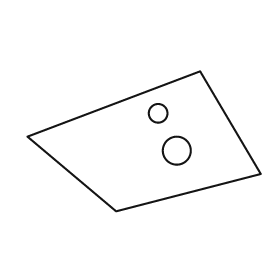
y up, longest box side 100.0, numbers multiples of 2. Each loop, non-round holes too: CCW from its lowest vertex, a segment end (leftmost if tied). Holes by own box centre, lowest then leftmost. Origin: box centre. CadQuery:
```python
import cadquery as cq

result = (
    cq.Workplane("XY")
    .moveTo(-12.0, -30.0)
    .lineTo(50.0, -14.0)
    .lineTo(24.0, 30.0)
    .lineTo(-50.0, 2.0)
    .close()
    .moveTo(14.0, -4.0)
    .circle(6.0)
    .moveTo(6.0, 12.0)
    .circle(4.0)
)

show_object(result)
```